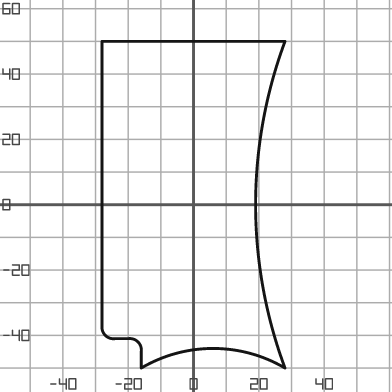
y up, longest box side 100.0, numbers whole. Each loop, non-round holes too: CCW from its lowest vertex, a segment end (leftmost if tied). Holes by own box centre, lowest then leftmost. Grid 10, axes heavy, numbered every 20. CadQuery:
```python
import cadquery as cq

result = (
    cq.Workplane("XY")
    .moveTo(-16.0, -50.0)
    .threePointArc((6.0, -44.0), (28.0, -50.0))
    .threePointArc((19.0, 0.0), (28.0, 50.0))
    .lineTo(-28.0, 50.0)
    .lineTo(-28.0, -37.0)
    .threePointArc((-27.0, -40.0), (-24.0, -41.0))
    .lineTo(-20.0, -41.0)
    .threePointArc((-17.0, -42.0), (-16.0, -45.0))
    .close()
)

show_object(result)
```